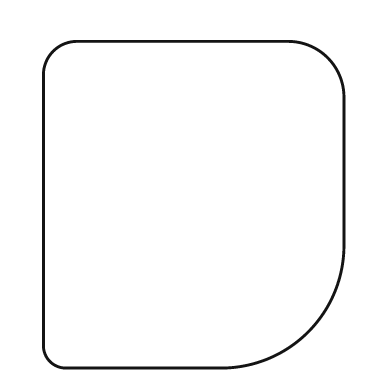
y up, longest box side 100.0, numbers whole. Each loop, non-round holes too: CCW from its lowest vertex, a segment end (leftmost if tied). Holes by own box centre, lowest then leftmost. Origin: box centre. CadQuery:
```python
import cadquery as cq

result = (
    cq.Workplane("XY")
    .moveTo(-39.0, -50.0)
    .lineTo(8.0, -50.0)
    .threePointArc((35.0, -39.0), (46.0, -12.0))
    .lineTo(46.0, 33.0)
    .threePointArc((41.0, 45.0), (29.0, 50.0))
    .lineTo(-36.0, 50.0)
    .threePointArc((-43.0, 47.0), (-46.0, 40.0))
    .lineTo(-46.0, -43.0)
    .threePointArc((-44.0, -48.0), (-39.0, -50.0))
    .close()
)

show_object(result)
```